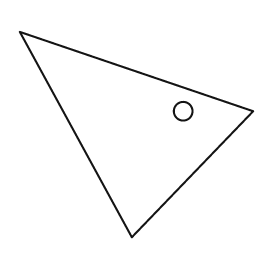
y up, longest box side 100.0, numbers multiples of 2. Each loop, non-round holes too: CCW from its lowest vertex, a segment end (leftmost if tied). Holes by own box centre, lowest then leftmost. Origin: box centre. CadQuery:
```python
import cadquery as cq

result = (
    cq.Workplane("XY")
    .moveTo(-2.0, -44.0)
    .lineTo(50.0, 10.0)
    .lineTo(-50.0, 44.0)
    .close()
    .moveTo(20.0, 10.0)
    .circle(4.0)
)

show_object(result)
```